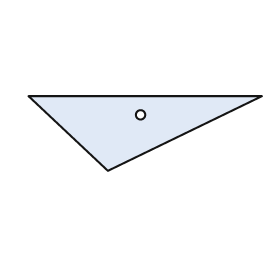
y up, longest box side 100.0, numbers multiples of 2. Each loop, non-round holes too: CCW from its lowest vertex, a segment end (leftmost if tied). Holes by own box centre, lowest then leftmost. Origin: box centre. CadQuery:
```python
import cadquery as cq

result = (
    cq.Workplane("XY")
    .moveTo(-16.0, -16.0)
    .lineTo(50.0, 16.0)
    .lineTo(-50.0, 16.0)
    .close()
    .moveTo(-2.0, 8.0)
    .circle(2.0)
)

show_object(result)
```